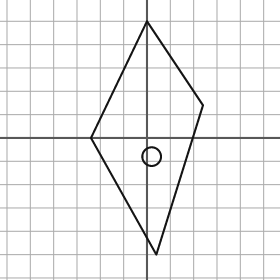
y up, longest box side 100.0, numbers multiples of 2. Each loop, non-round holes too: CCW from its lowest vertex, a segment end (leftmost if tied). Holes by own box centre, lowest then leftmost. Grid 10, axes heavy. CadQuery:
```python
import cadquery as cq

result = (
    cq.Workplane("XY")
    .moveTo(4.0, -50.0)
    .lineTo(24.0, 14.0)
    .lineTo(0.0, 50.0)
    .lineTo(-24.0, 0.0)
    .close()
    .moveTo(2.0, -8.0)
    .circle(4.0)
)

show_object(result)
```